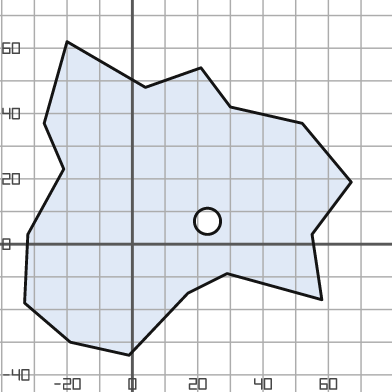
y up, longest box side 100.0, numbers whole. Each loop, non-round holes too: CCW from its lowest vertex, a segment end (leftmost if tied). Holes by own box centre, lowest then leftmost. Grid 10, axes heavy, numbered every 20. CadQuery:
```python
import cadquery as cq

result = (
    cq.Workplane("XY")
    .moveTo(-1.0, -34.0)
    .lineTo(17.0, -15.0)
    .lineTo(29.0, -9.0)
    .lineTo(58.0, -17.0)
    .lineTo(55.0, 3.0)
    .lineTo(67.0, 19.0)
    .lineTo(52.0, 37.0)
    .lineTo(30.0, 42.0)
    .lineTo(21.0, 54.0)
    .lineTo(4.0, 48.0)
    .lineTo(-20.0, 62.0)
    .lineTo(-27.0, 37.0)
    .lineTo(-21.0, 23.0)
    .lineTo(-32.0, 3.0)
    .lineTo(-33.0, -18.0)
    .lineTo(-19.0, -30.0)
    .close()
    .moveTo(23.0, 7.0)
    .circle(4.0)
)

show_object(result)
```